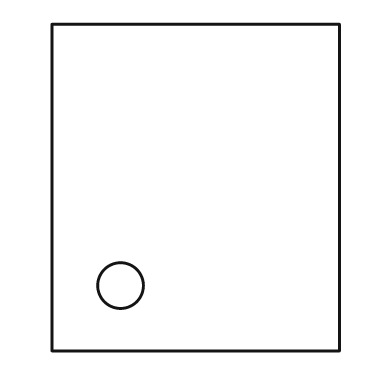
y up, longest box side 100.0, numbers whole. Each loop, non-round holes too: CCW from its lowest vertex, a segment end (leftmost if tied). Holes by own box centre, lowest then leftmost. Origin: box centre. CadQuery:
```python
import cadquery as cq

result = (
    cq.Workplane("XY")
    .moveTo(-44.0, -50.0)
    .lineTo(44.0, -50.0)
    .lineTo(44.0, 50.0)
    .lineTo(-44.0, 50.0)
    .close()
    .moveTo(-23.0, -30.0)
    .circle(7.0)
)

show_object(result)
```